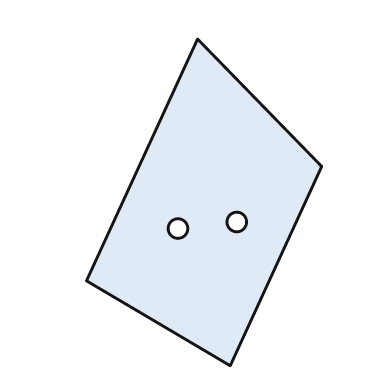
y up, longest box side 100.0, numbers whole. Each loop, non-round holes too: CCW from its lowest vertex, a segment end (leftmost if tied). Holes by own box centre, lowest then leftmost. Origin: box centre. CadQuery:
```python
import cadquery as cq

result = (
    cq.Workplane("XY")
    .moveTo(8.0, -50.0)
    .lineTo(36.0, 11.0)
    .lineTo(-2.0, 50.0)
    .lineTo(-36.0, -24.0)
    .close()
    .moveTo(-8.0, -8.0)
    .circle(3.0)
    .moveTo(10.0, -6.0)
    .circle(3.0)
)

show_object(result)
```